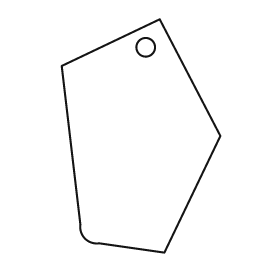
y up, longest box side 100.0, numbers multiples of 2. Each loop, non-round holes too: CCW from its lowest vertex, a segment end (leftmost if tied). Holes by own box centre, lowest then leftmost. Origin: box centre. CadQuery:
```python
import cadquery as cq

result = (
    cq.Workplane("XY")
    .moveTo(10.0, -50.0)
    .lineTo(34.0, 0.0)
    .lineTo(8.0, 50.0)
    .lineTo(-34.0, 30.0)
    .lineTo(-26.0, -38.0)
    .threePointArc((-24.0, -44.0), (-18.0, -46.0))
    .close()
    .moveTo(2.0, 38.0)
    .circle(4.0)
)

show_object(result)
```